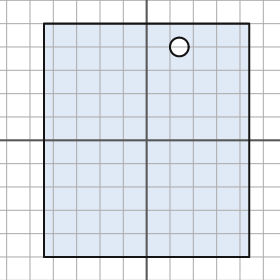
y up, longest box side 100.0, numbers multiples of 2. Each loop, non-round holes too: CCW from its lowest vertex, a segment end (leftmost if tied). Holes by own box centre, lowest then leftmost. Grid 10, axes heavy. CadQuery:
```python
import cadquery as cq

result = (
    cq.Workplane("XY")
    .moveTo(-44.0, -50.0)
    .lineTo(44.0, -50.0)
    .lineTo(44.0, 50.0)
    .lineTo(-44.0, 50.0)
    .close()
    .moveTo(14.0, 40.0)
    .circle(4.0)
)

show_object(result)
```